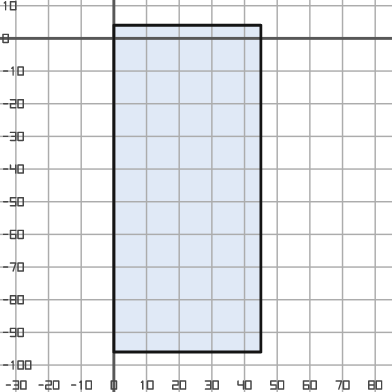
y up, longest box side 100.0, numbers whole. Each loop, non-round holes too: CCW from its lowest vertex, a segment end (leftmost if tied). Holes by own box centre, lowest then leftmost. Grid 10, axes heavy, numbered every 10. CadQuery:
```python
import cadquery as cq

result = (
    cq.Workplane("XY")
    .moveTo(0.0, -96.0)
    .lineTo(45.0, -96.0)
    .lineTo(45.0, 4.0)
    .lineTo(0.0, 4.0)
    .close()
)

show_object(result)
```